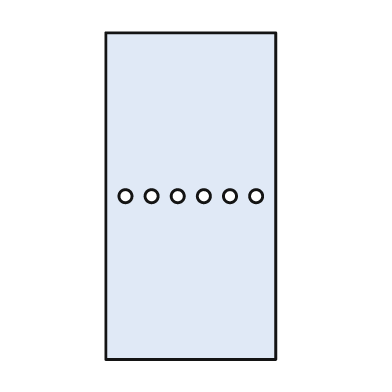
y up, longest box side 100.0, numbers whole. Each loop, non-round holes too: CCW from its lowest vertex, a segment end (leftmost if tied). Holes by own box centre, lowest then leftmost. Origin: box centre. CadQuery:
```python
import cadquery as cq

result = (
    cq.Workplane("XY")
    .moveTo(-26.0, -50.0)
    .lineTo(26.0, -50.0)
    .lineTo(26.0, 50.0)
    .lineTo(-26.0, 50.0)
    .close()
    .moveTo(-20.0, 0.0)
    .circle(2.0)
    .moveTo(-12.0, 0.0)
    .circle(2.0)
    .moveTo(-4.0, 0.0)
    .circle(2.0)
    .moveTo(4.0, 0.0)
    .circle(2.0)
    .moveTo(12.0, 0.0)
    .circle(2.0)
    .moveTo(20.0, 0.0)
    .circle(2.0)
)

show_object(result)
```